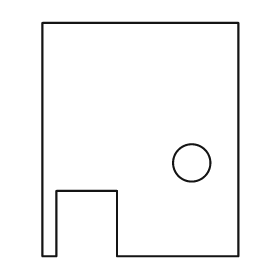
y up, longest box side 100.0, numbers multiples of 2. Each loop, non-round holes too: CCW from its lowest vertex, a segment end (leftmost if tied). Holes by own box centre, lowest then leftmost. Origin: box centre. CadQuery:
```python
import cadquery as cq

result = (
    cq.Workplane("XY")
    .moveTo(-42.0, -50.0)
    .lineTo(-36.0, -50.0)
    .lineTo(-36.0, -22.0)
    .lineTo(-10.0, -22.0)
    .lineTo(-10.0, -50.0)
    .lineTo(42.0, -50.0)
    .lineTo(42.0, 50.0)
    .lineTo(-42.0, 50.0)
    .close()
    .moveTo(22.0, -10.0)
    .circle(8.0)
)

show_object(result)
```